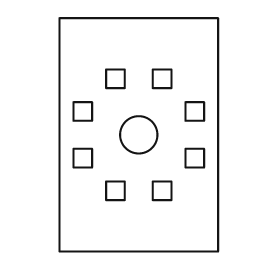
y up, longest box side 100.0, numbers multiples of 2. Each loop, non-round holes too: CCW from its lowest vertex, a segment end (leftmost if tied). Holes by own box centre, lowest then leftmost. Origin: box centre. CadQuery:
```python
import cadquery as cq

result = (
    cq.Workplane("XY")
    .moveTo(-34.0, -50.0)
    .lineTo(34.0, -50.0)
    .lineTo(34.0, 50.0)
    .lineTo(-34.0, 50.0)
    .close()
    .moveTo(-14.0, -28.0)
    .lineTo(-6.0, -28.0)
    .lineTo(-6.0, -20.0)
    .lineTo(-14.0, -20.0)
    .close()
    .moveTo(6.0, -28.0)
    .lineTo(14.0, -28.0)
    .lineTo(14.0, -20.0)
    .lineTo(6.0, -20.0)
    .close()
    .moveTo(-28.0, -14.0)
    .lineTo(-20.0, -14.0)
    .lineTo(-20.0, -6.0)
    .lineTo(-28.0, -6.0)
    .close()
    .moveTo(20.0, -14.0)
    .lineTo(28.0, -14.0)
    .lineTo(28.0, -6.0)
    .lineTo(20.0, -6.0)
    .close()
    .moveTo(0.0, 0.0)
    .circle(8.0)
    .moveTo(-28.0, 6.0)
    .lineTo(-20.0, 6.0)
    .lineTo(-20.0, 14.0)
    .lineTo(-28.0, 14.0)
    .close()
    .moveTo(20.0, 6.0)
    .lineTo(28.0, 6.0)
    .lineTo(28.0, 14.0)
    .lineTo(20.0, 14.0)
    .close()
    .moveTo(-14.0, 20.0)
    .lineTo(-6.0, 20.0)
    .lineTo(-6.0, 28.0)
    .lineTo(-14.0, 28.0)
    .close()
    .moveTo(6.0, 20.0)
    .lineTo(14.0, 20.0)
    .lineTo(14.0, 28.0)
    .lineTo(6.0, 28.0)
    .close()
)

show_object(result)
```